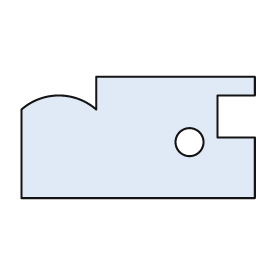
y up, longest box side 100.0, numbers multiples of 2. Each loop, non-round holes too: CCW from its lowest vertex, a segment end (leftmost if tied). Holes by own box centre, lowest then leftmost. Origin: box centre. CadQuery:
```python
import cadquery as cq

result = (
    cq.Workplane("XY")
    .moveTo(-50.0, -26.0)
    .lineTo(50.0, -26.0)
    .lineTo(50.0, 0.0)
    .lineTo(34.0, 0.0)
    .lineTo(34.0, 18.0)
    .lineTo(50.0, 18.0)
    .lineTo(50.0, 26.0)
    .lineTo(-18.0, 26.0)
    .lineTo(-18.0, 12.0)
    .threePointArc((-34.0, 18.0), (-50.0, 12.0))
    .close()
    .moveTo(22.0, -2.0)
    .circle(6.0)
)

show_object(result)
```